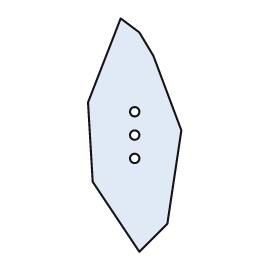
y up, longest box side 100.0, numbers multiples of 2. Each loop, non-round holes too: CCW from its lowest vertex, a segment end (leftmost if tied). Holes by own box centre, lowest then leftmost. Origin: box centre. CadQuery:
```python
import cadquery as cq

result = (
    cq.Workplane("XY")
    .moveTo(2.0, -50.0)
    .lineTo(14.0, -38.0)
    .lineTo(20.0, 2.0)
    .lineTo(8.0, 34.0)
    .lineTo(2.0, 44.0)
    .lineTo(-6.0, 50.0)
    .lineTo(-20.0, 14.0)
    .lineTo(-18.0, -20.0)
    .close()
    .moveTo(0.0, -10.0)
    .circle(2.0)
    .moveTo(0.0, 0.0)
    .circle(2.0)
    .moveTo(0.0, 10.0)
    .circle(2.0)
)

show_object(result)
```